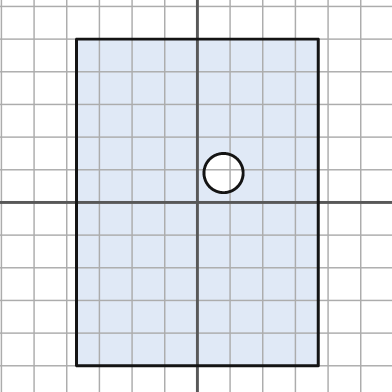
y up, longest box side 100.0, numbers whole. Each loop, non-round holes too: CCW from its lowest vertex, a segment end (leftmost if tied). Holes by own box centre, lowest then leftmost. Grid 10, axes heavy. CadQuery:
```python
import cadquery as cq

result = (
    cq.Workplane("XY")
    .moveTo(-37.0, -50.0)
    .lineTo(37.0, -50.0)
    .lineTo(37.0, 50.0)
    .lineTo(-37.0, 50.0)
    .close()
    .moveTo(8.0, 9.0)
    .circle(6.0)
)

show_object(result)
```